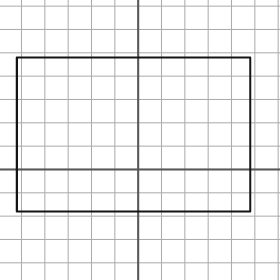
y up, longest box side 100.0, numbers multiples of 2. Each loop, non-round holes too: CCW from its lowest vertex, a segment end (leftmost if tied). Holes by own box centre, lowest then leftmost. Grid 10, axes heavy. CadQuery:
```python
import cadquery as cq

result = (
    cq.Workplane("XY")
    .moveTo(-52.0, -18.0)
    .lineTo(48.0, -18.0)
    .lineTo(48.0, 48.0)
    .lineTo(-52.0, 48.0)
    .close()
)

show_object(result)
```